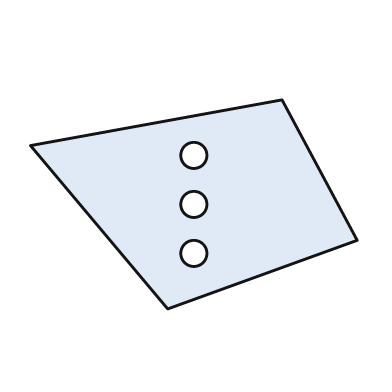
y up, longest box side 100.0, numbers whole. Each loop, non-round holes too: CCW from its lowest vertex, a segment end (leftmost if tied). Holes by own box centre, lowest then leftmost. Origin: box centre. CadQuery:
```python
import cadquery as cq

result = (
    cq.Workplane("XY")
    .moveTo(-8.0, -32.0)
    .lineTo(50.0, -11.0)
    .lineTo(27.0, 32.0)
    .lineTo(-50.0, 18.0)
    .close()
    .moveTo(0.0, -15.0)
    .circle(4.0)
    .moveTo(0.0, 0.0)
    .circle(4.0)
    .moveTo(0.0, 15.0)
    .circle(4.0)
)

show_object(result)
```